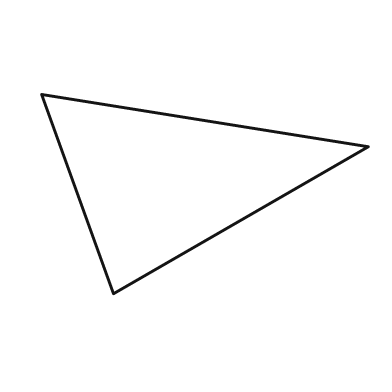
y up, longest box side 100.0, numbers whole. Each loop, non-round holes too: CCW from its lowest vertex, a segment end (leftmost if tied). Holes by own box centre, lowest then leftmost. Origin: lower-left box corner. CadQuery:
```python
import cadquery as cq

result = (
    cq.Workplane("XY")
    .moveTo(22.0, 0.0)
    .lineTo(100.0, 45.0)
    .lineTo(0.0, 61.0)
    .close()
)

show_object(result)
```